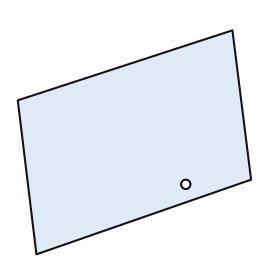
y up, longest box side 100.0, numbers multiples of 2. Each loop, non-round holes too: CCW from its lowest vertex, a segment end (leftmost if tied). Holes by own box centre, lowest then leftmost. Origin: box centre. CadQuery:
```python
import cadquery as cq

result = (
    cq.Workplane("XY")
    .moveTo(-42.0, -48.0)
    .lineTo(50.0, -16.0)
    .lineTo(42.0, 48.0)
    .lineTo(-50.0, 18.0)
    .close()
    .moveTo(22.0, -18.0)
    .circle(2.0)
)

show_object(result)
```